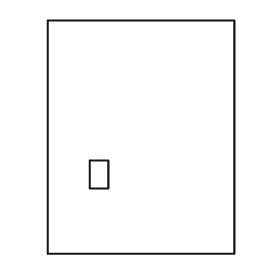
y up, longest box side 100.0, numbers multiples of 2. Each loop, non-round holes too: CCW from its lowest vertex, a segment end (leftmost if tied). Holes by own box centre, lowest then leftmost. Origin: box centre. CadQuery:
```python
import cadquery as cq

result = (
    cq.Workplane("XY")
    .moveTo(-40.0, -50.0)
    .lineTo(40.0, -50.0)
    .lineTo(40.0, 50.0)
    .lineTo(-40.0, 50.0)
    .close()
    .moveTo(-22.0, -22.0)
    .lineTo(-14.0, -22.0)
    .lineTo(-14.0, -10.0)
    .lineTo(-22.0, -10.0)
    .close()
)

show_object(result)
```